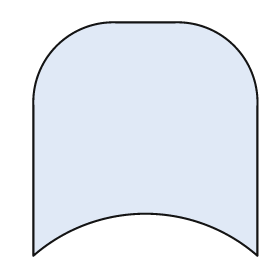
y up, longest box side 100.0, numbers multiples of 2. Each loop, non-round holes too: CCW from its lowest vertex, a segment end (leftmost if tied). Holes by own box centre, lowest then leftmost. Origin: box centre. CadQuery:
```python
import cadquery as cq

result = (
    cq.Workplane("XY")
    .moveTo(-48.0, -50.0)
    .threePointArc((0.0, -32.0), (48.0, -50.0))
    .lineTo(48.0, 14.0)
    .threePointArc((38.0, 40.0), (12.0, 50.0))
    .lineTo(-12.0, 50.0)
    .threePointArc((-38.0, 40.0), (-48.0, 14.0))
    .close()
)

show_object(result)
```